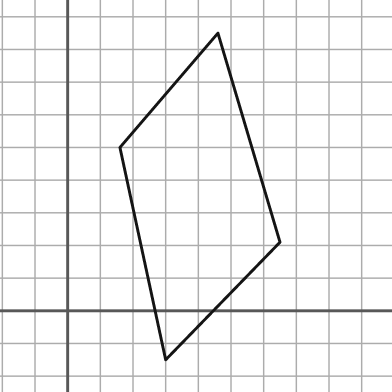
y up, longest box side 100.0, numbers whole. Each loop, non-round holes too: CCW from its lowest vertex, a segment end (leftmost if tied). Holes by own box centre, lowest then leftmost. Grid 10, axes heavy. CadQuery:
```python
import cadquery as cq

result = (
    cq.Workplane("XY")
    .moveTo(30.0, -15.0)
    .lineTo(65.0, 21.0)
    .lineTo(46.0, 85.0)
    .lineTo(16.0, 50.0)
    .close()
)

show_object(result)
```